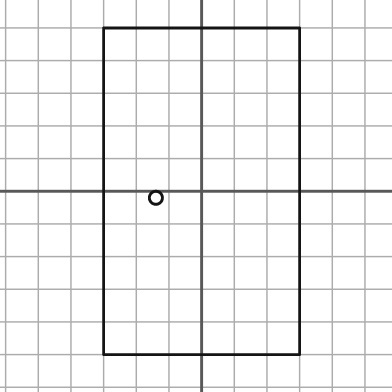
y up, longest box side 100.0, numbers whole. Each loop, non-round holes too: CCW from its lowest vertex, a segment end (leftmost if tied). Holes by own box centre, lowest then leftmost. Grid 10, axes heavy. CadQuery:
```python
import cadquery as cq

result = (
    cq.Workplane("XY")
    .moveTo(-30.0, -50.0)
    .lineTo(30.0, -50.0)
    .lineTo(30.0, 50.0)
    .lineTo(-30.0, 50.0)
    .close()
    .moveTo(-14.0, -2.0)
    .circle(2.0)
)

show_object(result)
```